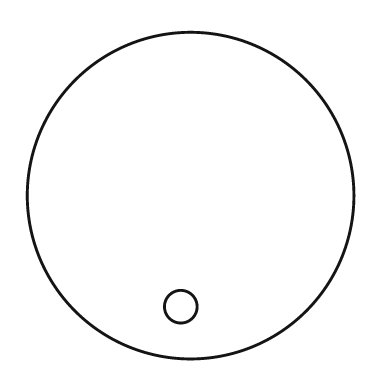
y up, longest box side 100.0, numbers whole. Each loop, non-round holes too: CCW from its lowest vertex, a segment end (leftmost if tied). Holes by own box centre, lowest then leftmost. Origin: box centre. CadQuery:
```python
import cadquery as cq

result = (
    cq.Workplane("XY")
    .moveTo(0.0, 0.0)
    .circle(50.0)
    .moveTo(-3.0, -34.0)
    .circle(5.0)
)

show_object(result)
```